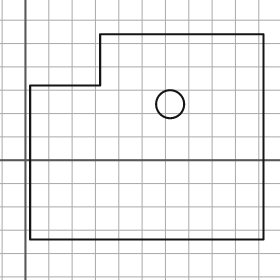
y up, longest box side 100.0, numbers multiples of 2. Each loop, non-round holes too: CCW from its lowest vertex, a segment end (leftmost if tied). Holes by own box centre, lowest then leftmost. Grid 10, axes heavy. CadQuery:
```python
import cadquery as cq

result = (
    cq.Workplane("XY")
    .moveTo(2.0, -34.0)
    .lineTo(102.0, -34.0)
    .lineTo(102.0, 54.0)
    .lineTo(32.0, 54.0)
    .lineTo(32.0, 32.0)
    .lineTo(2.0, 32.0)
    .close()
    .moveTo(62.0, 24.0)
    .circle(6.0)
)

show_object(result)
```